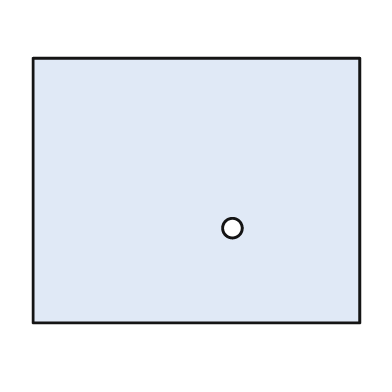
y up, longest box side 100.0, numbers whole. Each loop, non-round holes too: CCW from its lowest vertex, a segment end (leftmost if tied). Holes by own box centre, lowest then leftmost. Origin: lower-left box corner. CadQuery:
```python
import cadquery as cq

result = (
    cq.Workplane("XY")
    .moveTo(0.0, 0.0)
    .lineTo(100.0, 0.0)
    .lineTo(100.0, 81.0)
    .lineTo(0.0, 81.0)
    .close()
    .moveTo(61.0, 29.0)
    .circle(3.0)
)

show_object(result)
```